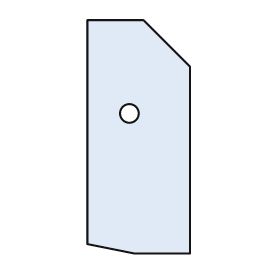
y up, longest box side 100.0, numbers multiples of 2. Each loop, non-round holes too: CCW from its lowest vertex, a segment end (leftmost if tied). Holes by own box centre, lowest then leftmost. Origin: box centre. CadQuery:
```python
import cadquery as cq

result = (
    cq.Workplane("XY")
    .moveTo(-2.0, -50.0)
    .lineTo(22.0, -50.0)
    .lineTo(22.0, 30.0)
    .lineTo(2.0, 50.0)
    .lineTo(-22.0, 50.0)
    .lineTo(-22.0, -46.0)
    .close()
    .moveTo(-4.0, 10.0)
    .circle(4.0)
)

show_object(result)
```